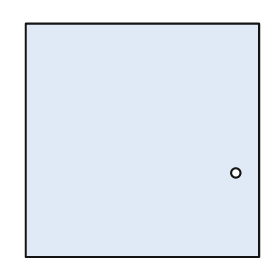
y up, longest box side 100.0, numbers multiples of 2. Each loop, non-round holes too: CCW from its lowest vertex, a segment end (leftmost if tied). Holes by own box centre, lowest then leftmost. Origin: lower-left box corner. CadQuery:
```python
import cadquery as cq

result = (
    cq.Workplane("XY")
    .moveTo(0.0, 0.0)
    .lineTo(100.0, 0.0)
    .lineTo(100.0, 100.0)
    .lineTo(0.0, 100.0)
    .close()
    .moveTo(90.0, 36.0)
    .circle(2.0)
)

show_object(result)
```